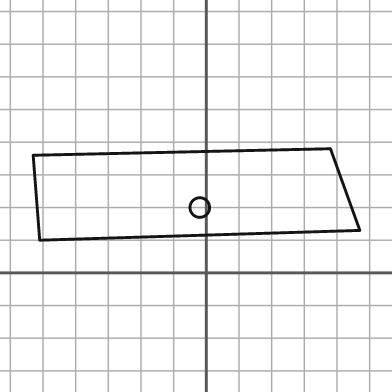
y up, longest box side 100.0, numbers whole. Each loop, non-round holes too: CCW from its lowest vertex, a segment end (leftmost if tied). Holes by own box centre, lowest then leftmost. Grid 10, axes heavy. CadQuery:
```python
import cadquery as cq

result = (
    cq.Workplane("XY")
    .moveTo(-51.0, 10.0)
    .lineTo(47.0, 13.0)
    .lineTo(38.0, 38.0)
    .lineTo(-53.0, 36.0)
    .close()
    .moveTo(-2.0, 20.0)
    .circle(3.0)
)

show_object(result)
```